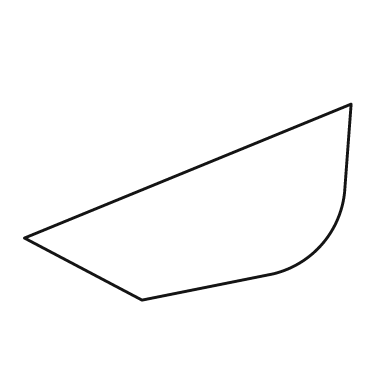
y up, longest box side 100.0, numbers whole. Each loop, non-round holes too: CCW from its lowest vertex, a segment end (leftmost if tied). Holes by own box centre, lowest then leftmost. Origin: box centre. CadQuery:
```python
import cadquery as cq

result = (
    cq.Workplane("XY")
    .moveTo(-14.0, -30.0)
    .lineTo(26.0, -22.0)
    .threePointArc((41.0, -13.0), (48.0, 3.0))
    .lineTo(50.0, 30.0)
    .lineTo(-50.0, -11.0)
    .close()
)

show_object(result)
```